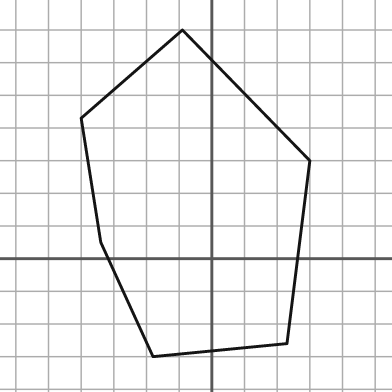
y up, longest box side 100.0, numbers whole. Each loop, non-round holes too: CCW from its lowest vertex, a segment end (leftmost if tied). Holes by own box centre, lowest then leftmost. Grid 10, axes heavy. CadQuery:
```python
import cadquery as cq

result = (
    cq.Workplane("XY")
    .moveTo(-18.0, -30.0)
    .lineTo(23.0, -26.0)
    .lineTo(30.0, 30.0)
    .lineTo(-9.0, 70.0)
    .lineTo(-40.0, 43.0)
    .lineTo(-34.0, 5.0)
    .close()
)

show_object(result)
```